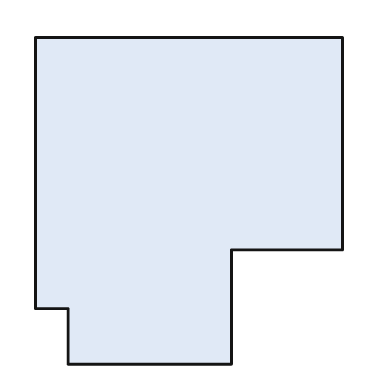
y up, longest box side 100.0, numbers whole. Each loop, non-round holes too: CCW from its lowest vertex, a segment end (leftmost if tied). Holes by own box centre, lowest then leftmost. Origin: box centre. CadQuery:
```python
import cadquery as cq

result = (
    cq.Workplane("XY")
    .moveTo(-37.0, -50.0)
    .lineTo(13.0, -50.0)
    .lineTo(13.0, -15.0)
    .lineTo(47.0, -15.0)
    .lineTo(47.0, 50.0)
    .lineTo(-47.0, 50.0)
    .lineTo(-47.0, -33.0)
    .lineTo(-37.0, -33.0)
    .close()
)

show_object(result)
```